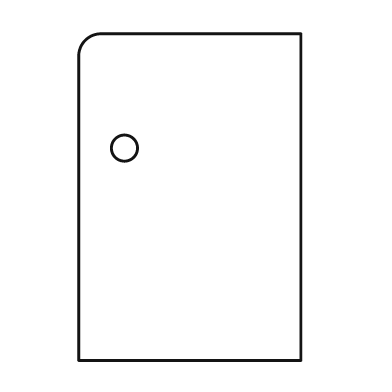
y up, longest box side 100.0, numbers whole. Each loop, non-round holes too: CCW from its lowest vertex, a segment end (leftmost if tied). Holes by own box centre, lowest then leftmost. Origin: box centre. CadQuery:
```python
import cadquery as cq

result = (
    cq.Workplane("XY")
    .moveTo(-34.0, -50.0)
    .lineTo(34.0, -50.0)
    .lineTo(34.0, 50.0)
    .lineTo(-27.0, 50.0)
    .threePointArc((-32.0, 48.0), (-34.0, 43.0))
    .close()
    .moveTo(-20.0, 15.0)
    .circle(4.0)
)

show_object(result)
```